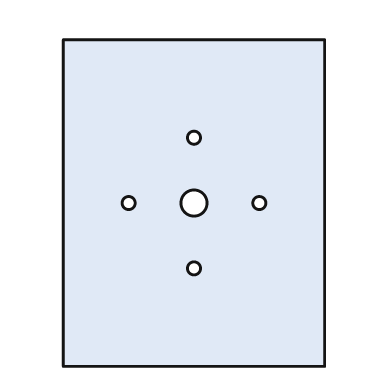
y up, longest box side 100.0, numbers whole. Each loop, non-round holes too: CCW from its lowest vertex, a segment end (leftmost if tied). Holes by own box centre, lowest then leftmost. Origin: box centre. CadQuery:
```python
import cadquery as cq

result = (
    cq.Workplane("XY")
    .moveTo(-40.0, -50.0)
    .lineTo(40.0, -50.0)
    .lineTo(40.0, 50.0)
    .lineTo(-40.0, 50.0)
    .close()
    .moveTo(0.0, -20.0)
    .circle(2.0)
    .moveTo(-20.0, 0.0)
    .circle(2.0)
    .moveTo(0.0, 0.0)
    .circle(4.0)
    .moveTo(20.0, 0.0)
    .circle(2.0)
    .moveTo(0.0, 20.0)
    .circle(2.0)
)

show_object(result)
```